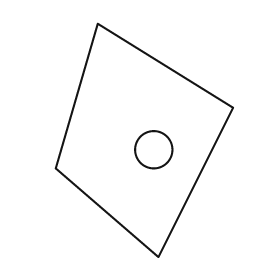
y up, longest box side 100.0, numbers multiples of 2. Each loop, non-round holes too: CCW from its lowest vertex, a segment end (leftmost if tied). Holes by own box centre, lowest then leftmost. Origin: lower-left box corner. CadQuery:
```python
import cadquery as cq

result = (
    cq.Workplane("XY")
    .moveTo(44.0, 0.0)
    .lineTo(76.0, 64.0)
    .lineTo(18.0, 100.0)
    .lineTo(0.0, 38.0)
    .close()
    .moveTo(42.0, 46.0)
    .circle(8.0)
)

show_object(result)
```